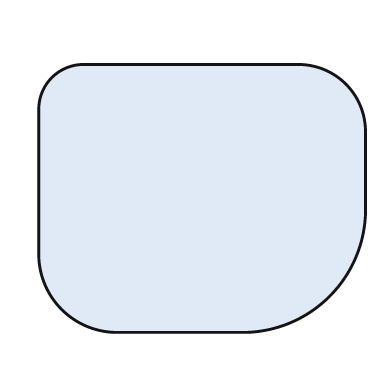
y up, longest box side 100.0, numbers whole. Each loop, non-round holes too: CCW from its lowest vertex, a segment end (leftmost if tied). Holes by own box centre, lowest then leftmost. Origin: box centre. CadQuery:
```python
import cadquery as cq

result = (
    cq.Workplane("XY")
    .moveTo(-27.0, -41.0)
    .lineTo(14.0, -41.0)
    .threePointArc((39.0, -30.0), (50.0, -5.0))
    .lineTo(50.0, 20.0)
    .threePointArc((44.0, 35.0), (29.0, 41.0))
    .lineTo(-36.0, 41.0)
    .threePointArc((-46.0, 37.0), (-50.0, 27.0))
    .lineTo(-50.0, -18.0)
    .threePointArc((-43.0, -34.0), (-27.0, -41.0))
    .close()
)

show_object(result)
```